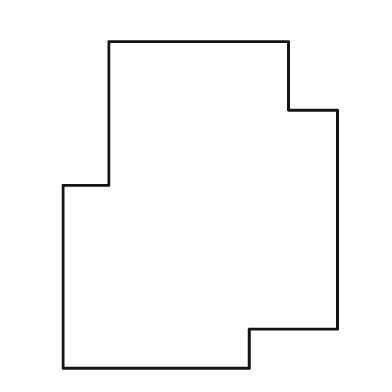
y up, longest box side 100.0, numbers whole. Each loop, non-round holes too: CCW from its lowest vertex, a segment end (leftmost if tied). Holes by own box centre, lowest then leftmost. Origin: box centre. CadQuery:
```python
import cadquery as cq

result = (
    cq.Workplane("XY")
    .moveTo(-42.0, -50.0)
    .lineTo(15.0, -50.0)
    .lineTo(15.0, -38.0)
    .lineTo(42.0, -38.0)
    .lineTo(42.0, 29.0)
    .lineTo(27.0, 29.0)
    .lineTo(27.0, 50.0)
    .lineTo(-28.0, 50.0)
    .lineTo(-28.0, 6.0)
    .lineTo(-42.0, 6.0)
    .close()
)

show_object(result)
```